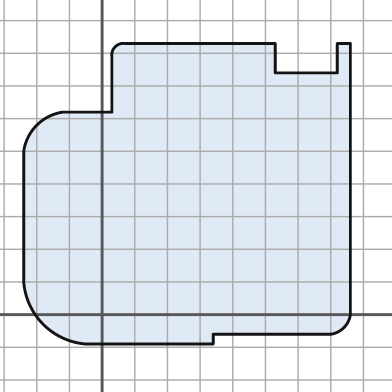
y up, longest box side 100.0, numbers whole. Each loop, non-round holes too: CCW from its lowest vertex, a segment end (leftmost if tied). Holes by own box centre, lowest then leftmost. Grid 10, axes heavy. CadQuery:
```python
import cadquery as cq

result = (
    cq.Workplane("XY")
    .moveTo(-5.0, -9.0)
    .lineTo(34.0, -9.0)
    .lineTo(34.0, -6.0)
    .lineTo(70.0, -6.0)
    .threePointArc((74.0, -4.0), (76.0, 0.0))
    .lineTo(76.0, 83.0)
    .lineTo(72.0, 83.0)
    .lineTo(72.0, 74.0)
    .lineTo(53.0, 74.0)
    .lineTo(53.0, 83.0)
    .lineTo(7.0, 83.0)
    .threePointArc((4.0, 82.0), (3.0, 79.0))
    .lineTo(3.0, 62.0)
    .lineTo(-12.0, 62.0)
    .threePointArc((-20.0, 58.0), (-24.0, 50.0))
    .lineTo(-24.0, 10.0)
    .threePointArc((-18.0, -3.0), (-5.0, -9.0))
    .close()
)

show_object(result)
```